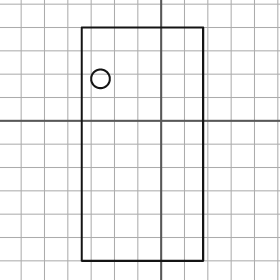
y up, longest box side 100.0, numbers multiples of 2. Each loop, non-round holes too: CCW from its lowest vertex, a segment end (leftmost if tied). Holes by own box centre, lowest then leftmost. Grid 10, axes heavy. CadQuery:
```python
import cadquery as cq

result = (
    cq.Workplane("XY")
    .moveTo(-34.0, -60.0)
    .lineTo(18.0, -60.0)
    .lineTo(18.0, 40.0)
    .lineTo(-34.0, 40.0)
    .close()
    .moveTo(-26.0, 18.0)
    .circle(4.0)
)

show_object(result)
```